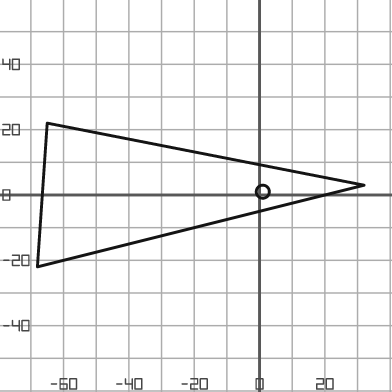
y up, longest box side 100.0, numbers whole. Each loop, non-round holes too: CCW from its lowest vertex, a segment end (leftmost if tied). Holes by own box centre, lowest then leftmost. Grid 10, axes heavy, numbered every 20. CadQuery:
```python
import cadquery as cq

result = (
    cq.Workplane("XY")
    .moveTo(-68.0, -22.0)
    .lineTo(32.0, 3.0)
    .lineTo(-65.0, 22.0)
    .close()
    .moveTo(1.0, 1.0)
    .circle(2.0)
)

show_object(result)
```